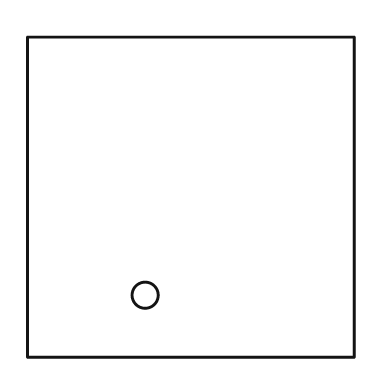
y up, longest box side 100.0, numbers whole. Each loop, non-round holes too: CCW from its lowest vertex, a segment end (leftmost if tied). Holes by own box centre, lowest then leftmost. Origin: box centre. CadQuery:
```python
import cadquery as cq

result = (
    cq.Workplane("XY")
    .moveTo(-50.0, -49.0)
    .lineTo(50.0, -49.0)
    .lineTo(50.0, 49.0)
    .lineTo(-50.0, 49.0)
    .close()
    .moveTo(-14.0, -30.0)
    .circle(4.0)
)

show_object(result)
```